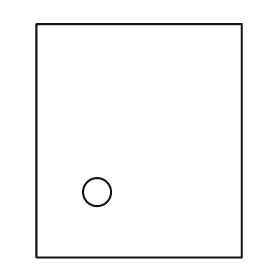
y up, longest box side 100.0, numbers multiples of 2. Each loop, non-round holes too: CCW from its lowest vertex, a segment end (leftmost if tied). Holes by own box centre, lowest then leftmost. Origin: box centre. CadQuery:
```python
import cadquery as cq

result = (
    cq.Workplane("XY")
    .moveTo(-44.0, -50.0)
    .lineTo(44.0, -50.0)
    .lineTo(44.0, 50.0)
    .lineTo(-44.0, 50.0)
    .close()
    .moveTo(-18.0, -22.0)
    .circle(6.0)
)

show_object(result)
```